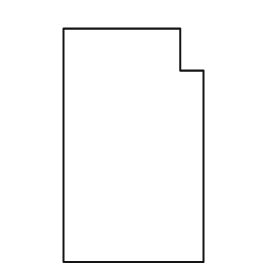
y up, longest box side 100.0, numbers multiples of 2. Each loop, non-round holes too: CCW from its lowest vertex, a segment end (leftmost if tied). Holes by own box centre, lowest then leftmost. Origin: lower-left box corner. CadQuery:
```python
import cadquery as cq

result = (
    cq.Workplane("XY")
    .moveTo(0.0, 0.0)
    .lineTo(60.0, 0.0)
    .lineTo(60.0, 82.0)
    .lineTo(50.0, 82.0)
    .lineTo(50.0, 100.0)
    .lineTo(0.0, 100.0)
    .close()
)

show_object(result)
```